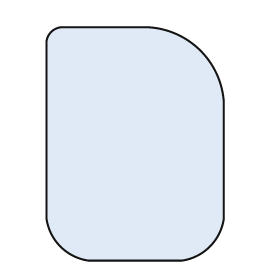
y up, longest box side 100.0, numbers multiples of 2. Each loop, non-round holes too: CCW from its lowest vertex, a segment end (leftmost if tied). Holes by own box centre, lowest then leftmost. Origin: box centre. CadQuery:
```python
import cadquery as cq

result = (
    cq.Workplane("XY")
    .moveTo(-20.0, -50.0)
    .lineTo(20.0, -50.0)
    .threePointArc((32.0, -44.0), (38.0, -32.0))
    .lineTo(38.0, 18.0)
    .threePointArc((28.0, 40.0), (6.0, 50.0))
    .lineTo(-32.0, 50.0)
    .threePointArc((-36.0, 48.0), (-38.0, 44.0))
    .lineTo(-38.0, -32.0)
    .threePointArc((-32.0, -44.0), (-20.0, -50.0))
    .close()
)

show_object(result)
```